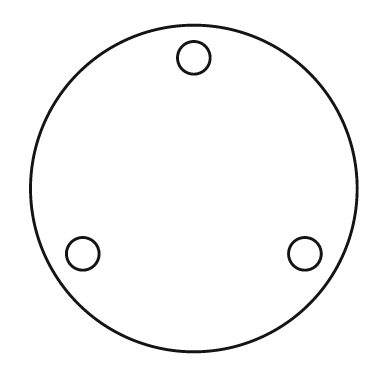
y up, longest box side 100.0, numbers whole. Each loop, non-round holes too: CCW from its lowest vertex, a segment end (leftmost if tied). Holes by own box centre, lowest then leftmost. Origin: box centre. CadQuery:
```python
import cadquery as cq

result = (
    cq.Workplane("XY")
    .moveTo(0.0, 0.0)
    .circle(50.0)
    .moveTo(-34.0, -20.0)
    .circle(5.0)
    .moveTo(34.0, -20.0)
    .circle(5.0)
    .moveTo(0.0, 40.0)
    .circle(5.0)
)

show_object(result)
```